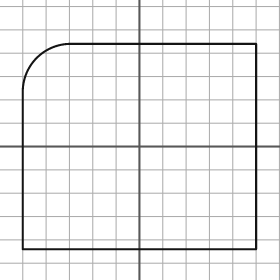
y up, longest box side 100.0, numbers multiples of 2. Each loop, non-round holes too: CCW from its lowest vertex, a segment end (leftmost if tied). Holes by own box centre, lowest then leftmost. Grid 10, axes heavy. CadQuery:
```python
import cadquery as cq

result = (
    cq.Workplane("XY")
    .moveTo(-50.0, -44.0)
    .lineTo(50.0, -44.0)
    .lineTo(50.0, 44.0)
    .lineTo(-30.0, 44.0)
    .threePointArc((-44.0, 38.0), (-50.0, 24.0))
    .close()
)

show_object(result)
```